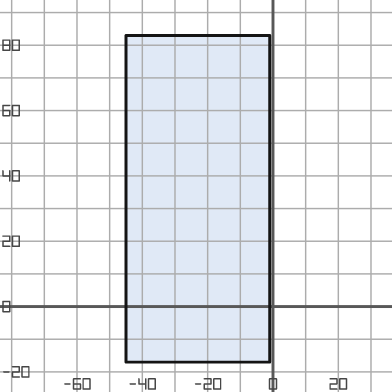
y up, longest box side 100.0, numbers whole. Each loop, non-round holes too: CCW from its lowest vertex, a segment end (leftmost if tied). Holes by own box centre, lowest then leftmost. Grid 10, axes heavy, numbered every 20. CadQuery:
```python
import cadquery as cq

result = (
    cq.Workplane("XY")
    .moveTo(-45.0, -17.0)
    .lineTo(-1.0, -17.0)
    .lineTo(-1.0, 83.0)
    .lineTo(-45.0, 83.0)
    .close()
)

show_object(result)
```